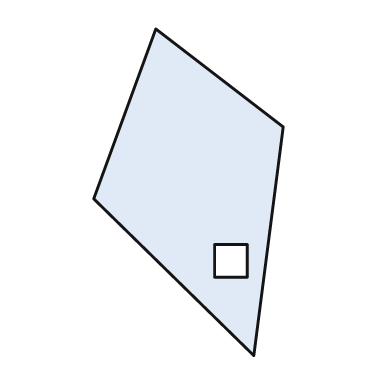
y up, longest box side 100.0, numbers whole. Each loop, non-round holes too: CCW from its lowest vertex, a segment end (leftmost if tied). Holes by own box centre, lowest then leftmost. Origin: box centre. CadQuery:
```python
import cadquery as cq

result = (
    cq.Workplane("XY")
    .moveTo(20.0, -50.0)
    .lineTo(29.0, 20.0)
    .lineTo(-10.0, 50.0)
    .lineTo(-29.0, -2.0)
    .close()
    .moveTo(8.0, -26.0)
    .lineTo(18.0, -26.0)
    .lineTo(18.0, -16.0)
    .lineTo(8.0, -16.0)
    .close()
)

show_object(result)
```